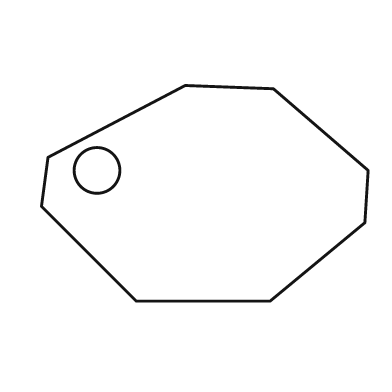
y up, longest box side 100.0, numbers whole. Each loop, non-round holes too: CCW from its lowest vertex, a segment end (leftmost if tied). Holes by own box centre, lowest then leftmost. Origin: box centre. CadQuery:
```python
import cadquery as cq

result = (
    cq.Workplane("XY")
    .moveTo(-21.0, -33.0)
    .lineTo(20.0, -33.0)
    .lineTo(49.0, -9.0)
    .lineTo(50.0, 7.0)
    .lineTo(21.0, 32.0)
    .lineTo(-6.0, 33.0)
    .lineTo(-48.0, 11.0)
    .lineTo(-50.0, -4.0)
    .close()
    .moveTo(-33.0, 7.0)
    .circle(7.0)
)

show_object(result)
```